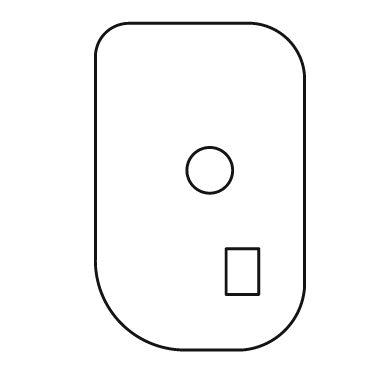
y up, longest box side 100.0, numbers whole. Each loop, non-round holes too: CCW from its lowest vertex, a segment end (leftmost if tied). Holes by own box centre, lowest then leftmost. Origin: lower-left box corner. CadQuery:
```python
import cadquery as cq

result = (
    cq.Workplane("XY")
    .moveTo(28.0, 0.0)
    .lineTo(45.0, 0.0)
    .threePointArc((58.0, 6.0), (64.0, 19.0))
    .lineTo(64.0, 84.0)
    .threePointArc((59.0, 95.0), (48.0, 100.0))
    .lineTo(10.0, 100.0)
    .threePointArc((3.0, 97.0), (0.0, 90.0))
    .lineTo(0.0, 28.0)
    .threePointArc((8.0, 8.0), (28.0, 0.0))
    .close()
    .moveTo(40.0, 17.0)
    .lineTo(50.0, 17.0)
    .lineTo(50.0, 31.0)
    .lineTo(40.0, 31.0)
    .close()
    .moveTo(35.0, 55.0)
    .circle(7.0)
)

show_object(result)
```